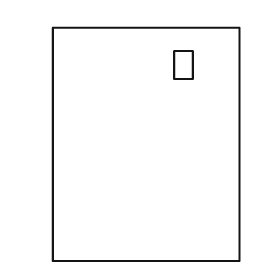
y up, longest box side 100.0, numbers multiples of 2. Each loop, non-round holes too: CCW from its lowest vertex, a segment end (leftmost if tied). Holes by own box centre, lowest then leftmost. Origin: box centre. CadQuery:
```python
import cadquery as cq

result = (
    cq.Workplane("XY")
    .moveTo(-40.0, -50.0)
    .lineTo(40.0, -50.0)
    .lineTo(40.0, 50.0)
    .lineTo(-40.0, 50.0)
    .close()
    .moveTo(12.0, 28.0)
    .lineTo(20.0, 28.0)
    .lineTo(20.0, 40.0)
    .lineTo(12.0, 40.0)
    .close()
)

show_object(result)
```